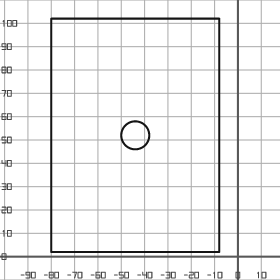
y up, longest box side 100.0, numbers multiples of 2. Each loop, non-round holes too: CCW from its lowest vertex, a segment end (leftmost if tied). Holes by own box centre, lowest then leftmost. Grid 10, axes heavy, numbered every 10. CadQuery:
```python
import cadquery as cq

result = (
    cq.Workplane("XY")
    .moveTo(-80.0, 2.0)
    .lineTo(-8.0, 2.0)
    .lineTo(-8.0, 102.0)
    .lineTo(-80.0, 102.0)
    .close()
    .moveTo(-44.0, 52.0)
    .circle(6.0)
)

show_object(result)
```